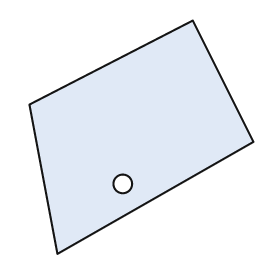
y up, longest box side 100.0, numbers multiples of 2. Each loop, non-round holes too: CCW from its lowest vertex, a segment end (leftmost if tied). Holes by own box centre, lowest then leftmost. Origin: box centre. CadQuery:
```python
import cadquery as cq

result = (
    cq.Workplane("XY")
    .moveTo(-36.0, -50.0)
    .lineTo(48.0, -2.0)
    .lineTo(22.0, 50.0)
    .lineTo(-48.0, 14.0)
    .close()
    .moveTo(-8.0, -20.0)
    .circle(4.0)
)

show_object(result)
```